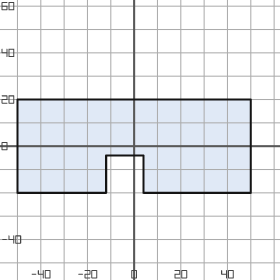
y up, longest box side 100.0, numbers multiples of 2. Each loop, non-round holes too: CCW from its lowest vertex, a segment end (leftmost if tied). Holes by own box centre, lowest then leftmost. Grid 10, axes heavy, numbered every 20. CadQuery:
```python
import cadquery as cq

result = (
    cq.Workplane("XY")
    .moveTo(-50.0, -20.0)
    .lineTo(-12.0, -20.0)
    .lineTo(-12.0, -4.0)
    .lineTo(4.0, -4.0)
    .lineTo(4.0, -20.0)
    .lineTo(50.0, -20.0)
    .lineTo(50.0, 20.0)
    .lineTo(-50.0, 20.0)
    .close()
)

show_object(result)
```